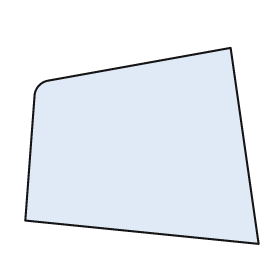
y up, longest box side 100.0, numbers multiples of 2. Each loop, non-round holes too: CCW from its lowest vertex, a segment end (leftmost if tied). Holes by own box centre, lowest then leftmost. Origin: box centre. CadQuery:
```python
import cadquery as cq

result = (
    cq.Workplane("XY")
    .moveTo(50.0, -42.0)
    .lineTo(38.0, 42.0)
    .lineTo(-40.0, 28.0)
    .threePointArc((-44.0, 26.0), (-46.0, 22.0))
    .lineTo(-50.0, -32.0)
    .close()
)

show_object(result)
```